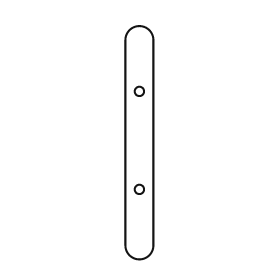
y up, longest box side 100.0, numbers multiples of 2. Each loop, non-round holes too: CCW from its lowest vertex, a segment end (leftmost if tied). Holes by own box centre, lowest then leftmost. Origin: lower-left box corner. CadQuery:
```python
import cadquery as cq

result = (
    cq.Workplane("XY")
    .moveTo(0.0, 6.0)
    .threePointArc((6.0, 0.0), (12.0, 6.0))
    .lineTo(12.0, 94.0)
    .threePointArc((6.0, 100.0), (0.0, 94.0))
    .close()
    .moveTo(6.0, 30.0)
    .circle(2.0)
    .moveTo(6.0, 72.0)
    .circle(2.0)
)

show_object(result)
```